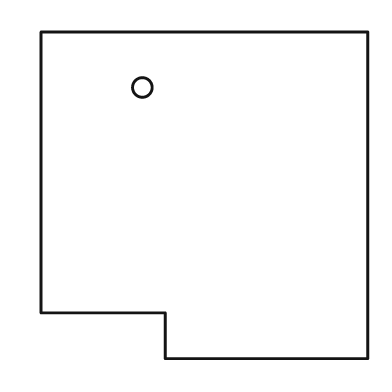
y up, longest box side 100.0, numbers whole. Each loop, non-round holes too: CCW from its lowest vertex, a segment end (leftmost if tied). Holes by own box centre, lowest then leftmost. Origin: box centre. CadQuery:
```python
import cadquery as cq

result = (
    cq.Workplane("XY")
    .moveTo(-12.0, -50.0)
    .lineTo(50.0, -50.0)
    .lineTo(50.0, 50.0)
    .lineTo(-50.0, 50.0)
    .lineTo(-50.0, -36.0)
    .lineTo(-12.0, -36.0)
    .close()
    .moveTo(-19.0, 33.0)
    .circle(3.0)
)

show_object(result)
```